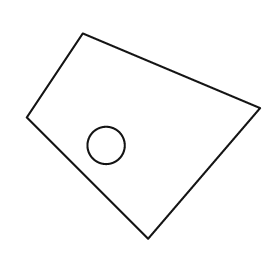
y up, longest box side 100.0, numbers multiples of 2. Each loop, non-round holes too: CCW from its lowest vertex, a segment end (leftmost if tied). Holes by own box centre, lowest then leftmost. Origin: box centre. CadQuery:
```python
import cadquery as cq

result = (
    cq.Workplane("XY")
    .moveTo(2.0, -44.0)
    .lineTo(50.0, 12.0)
    .lineTo(-26.0, 44.0)
    .lineTo(-50.0, 8.0)
    .close()
    .moveTo(-16.0, -4.0)
    .circle(8.0)
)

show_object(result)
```